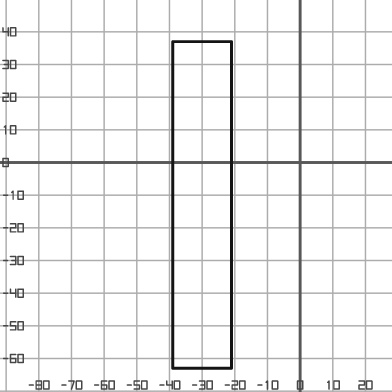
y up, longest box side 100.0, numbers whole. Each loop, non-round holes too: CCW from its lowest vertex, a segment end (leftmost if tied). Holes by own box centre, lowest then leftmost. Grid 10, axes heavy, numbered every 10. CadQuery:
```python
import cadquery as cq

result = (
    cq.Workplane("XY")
    .moveTo(-39.0, -63.0)
    .lineTo(-21.0, -63.0)
    .lineTo(-21.0, 37.0)
    .lineTo(-39.0, 37.0)
    .close()
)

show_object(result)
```